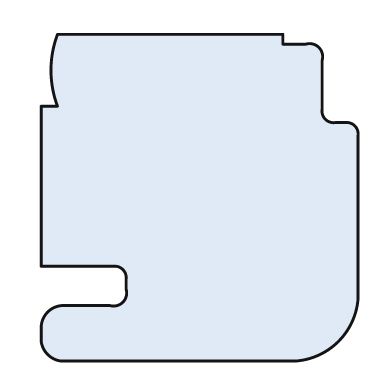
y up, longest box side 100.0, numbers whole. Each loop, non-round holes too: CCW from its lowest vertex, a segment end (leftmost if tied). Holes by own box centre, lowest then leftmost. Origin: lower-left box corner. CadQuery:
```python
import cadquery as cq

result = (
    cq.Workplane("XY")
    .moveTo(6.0, 0.0)
    .lineTo(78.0, 0.0)
    .threePointArc((91.0, 6.0), (97.0, 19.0))
    .lineTo(97.0, 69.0)
    .threePointArc((96.0, 72.0), (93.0, 73.0))
    .lineTo(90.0, 73.0)
    .threePointArc((87.0, 74.0), (86.0, 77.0))
    .lineTo(86.0, 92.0)
    .threePointArc((85.0, 96.0), (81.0, 97.0))
    .lineTo(74.0, 97.0)
    .lineTo(74.0, 100.0)
    .lineTo(5.0, 100.0)
    .threePointArc((3.0, 89.0), (5.0, 78.0))
    .lineTo(0.0, 78.0)
    .lineTo(0.0, 29.0)
    .lineTo(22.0, 29.0)
    .threePointArc((25.0, 28.0), (26.0, 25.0))
    .lineTo(26.0, 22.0)
    .threePointArc((25.0, 18.0), (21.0, 17.0))
    .lineTo(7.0, 17.0)
    .threePointArc((2.0, 15.0), (0.0, 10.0))
    .lineTo(0.0, 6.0)
    .threePointArc((2.0, 2.0), (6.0, 0.0))
    .close()
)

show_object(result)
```